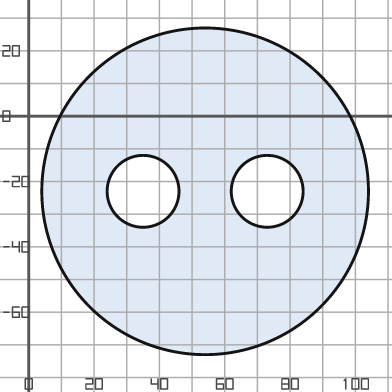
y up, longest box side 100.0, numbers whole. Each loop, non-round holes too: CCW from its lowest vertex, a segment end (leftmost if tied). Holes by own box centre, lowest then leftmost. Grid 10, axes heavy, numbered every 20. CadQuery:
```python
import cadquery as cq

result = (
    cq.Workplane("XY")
    .moveTo(54.0, -23.0)
    .circle(50.0)
    .moveTo(35.0, -23.0)
    .circle(11.0)
    .moveTo(73.0, -23.0)
    .circle(11.0)
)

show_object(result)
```